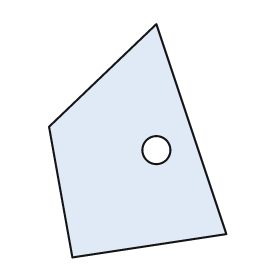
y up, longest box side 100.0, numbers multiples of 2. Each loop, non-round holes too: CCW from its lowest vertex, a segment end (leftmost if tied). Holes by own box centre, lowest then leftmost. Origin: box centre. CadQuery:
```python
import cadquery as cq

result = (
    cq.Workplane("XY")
    .moveTo(-28.0, -50.0)
    .lineTo(38.0, -40.0)
    .lineTo(8.0, 50.0)
    .lineTo(-38.0, 6.0)
    .close()
    .moveTo(8.0, -4.0)
    .circle(6.0)
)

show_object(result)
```